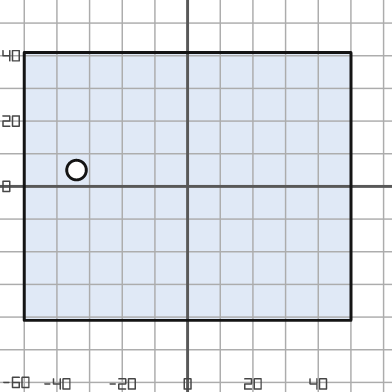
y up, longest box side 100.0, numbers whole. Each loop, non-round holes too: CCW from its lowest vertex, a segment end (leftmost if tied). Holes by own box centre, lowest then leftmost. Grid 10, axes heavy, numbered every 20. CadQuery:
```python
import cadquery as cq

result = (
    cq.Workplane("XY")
    .moveTo(-50.0, -41.0)
    .lineTo(50.0, -41.0)
    .lineTo(50.0, 41.0)
    .lineTo(-50.0, 41.0)
    .close()
    .moveTo(-34.0, 5.0)
    .circle(3.0)
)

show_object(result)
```